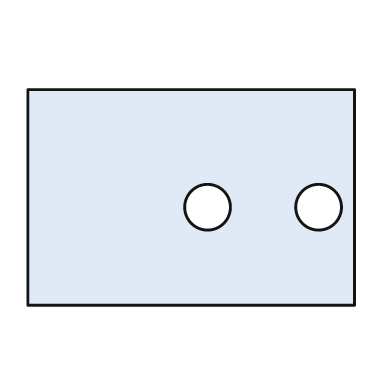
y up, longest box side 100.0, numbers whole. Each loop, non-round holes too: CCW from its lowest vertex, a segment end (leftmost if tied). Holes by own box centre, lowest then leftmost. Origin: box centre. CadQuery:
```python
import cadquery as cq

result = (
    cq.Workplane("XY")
    .moveTo(-50.0, -33.0)
    .lineTo(50.0, -33.0)
    .lineTo(50.0, 33.0)
    .lineTo(-50.0, 33.0)
    .close()
    .moveTo(5.0, -3.0)
    .circle(7.0)
    .moveTo(39.0, -3.0)
    .circle(7.0)
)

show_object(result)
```